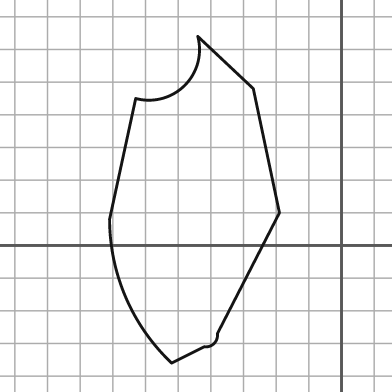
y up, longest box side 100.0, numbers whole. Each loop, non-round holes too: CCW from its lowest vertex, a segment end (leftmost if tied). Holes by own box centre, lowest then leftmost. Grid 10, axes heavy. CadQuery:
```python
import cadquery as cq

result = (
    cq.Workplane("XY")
    .moveTo(-52.0, -36.0)
    .lineTo(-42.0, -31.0)
    .threePointArc((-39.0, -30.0), (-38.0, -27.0))
    .lineTo(-19.0, 10.0)
    .lineTo(-27.0, 48.0)
    .lineTo(-44.0, 64.0)
    .threePointArc((-48.0, 49.0), (-63.0, 45.0))
    .lineTo(-71.0, 8.0)
    .threePointArc((-66.0, -16.0), (-52.0, -36.0))
    .close()
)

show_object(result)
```